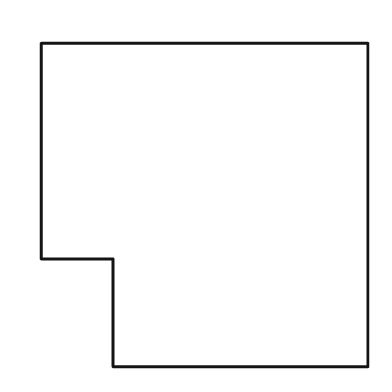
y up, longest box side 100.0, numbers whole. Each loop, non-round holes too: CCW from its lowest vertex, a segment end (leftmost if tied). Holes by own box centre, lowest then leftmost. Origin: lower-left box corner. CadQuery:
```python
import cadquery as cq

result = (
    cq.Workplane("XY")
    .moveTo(22.0, 0.0)
    .lineTo(100.0, 0.0)
    .lineTo(100.0, 99.0)
    .lineTo(0.0, 99.0)
    .lineTo(0.0, 33.0)
    .lineTo(22.0, 33.0)
    .close()
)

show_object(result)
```